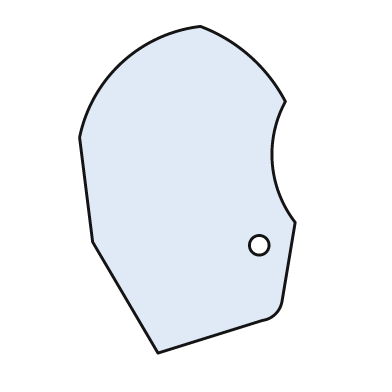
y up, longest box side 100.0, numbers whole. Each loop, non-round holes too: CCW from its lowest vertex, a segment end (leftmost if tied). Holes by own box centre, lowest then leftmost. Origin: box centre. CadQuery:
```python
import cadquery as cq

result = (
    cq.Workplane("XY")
    .moveTo(-9.0, -50.0)
    .lineTo(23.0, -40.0)
    .threePointArc((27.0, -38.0), (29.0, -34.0))
    .lineTo(33.0, -10.0)
    .threePointArc((26.0, 8.0), (30.0, 27.0))
    .threePointArc((19.0, 41.0), (4.0, 50.0))
    .threePointArc((-20.0, 39.0), (-33.0, 16.0))
    .lineTo(-29.0, -16.0)
    .close()
    .moveTo(22.0, -17.0)
    .circle(3.0)
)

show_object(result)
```